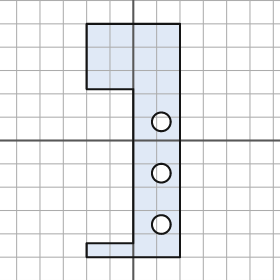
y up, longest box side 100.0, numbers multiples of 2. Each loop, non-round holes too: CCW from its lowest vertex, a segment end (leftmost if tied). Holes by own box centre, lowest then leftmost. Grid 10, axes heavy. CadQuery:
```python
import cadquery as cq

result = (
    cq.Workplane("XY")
    .moveTo(-20.0, -50.0)
    .lineTo(20.0, -50.0)
    .lineTo(20.0, 50.0)
    .lineTo(-20.0, 50.0)
    .lineTo(-20.0, 22.0)
    .lineTo(0.0, 22.0)
    .lineTo(0.0, -44.0)
    .lineTo(-20.0, -44.0)
    .close()
    .moveTo(12.0, -36.0)
    .circle(4.0)
    .moveTo(12.0, -14.0)
    .circle(4.0)
    .moveTo(12.0, 8.0)
    .circle(4.0)
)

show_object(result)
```